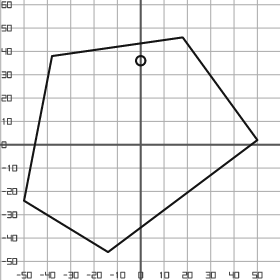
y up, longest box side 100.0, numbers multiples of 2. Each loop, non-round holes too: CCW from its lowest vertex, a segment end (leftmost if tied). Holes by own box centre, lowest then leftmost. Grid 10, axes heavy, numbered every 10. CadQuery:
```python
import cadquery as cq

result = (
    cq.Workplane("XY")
    .moveTo(-14.0, -46.0)
    .lineTo(50.0, 2.0)
    .lineTo(18.0, 46.0)
    .lineTo(-38.0, 38.0)
    .lineTo(-50.0, -24.0)
    .close()
    .moveTo(0.0, 36.0)
    .circle(2.0)
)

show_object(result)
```